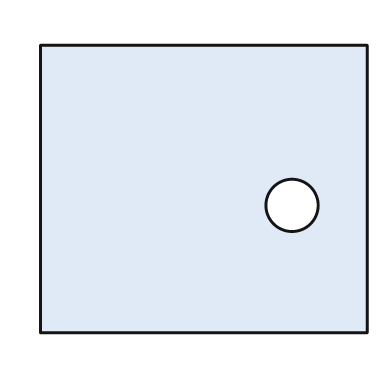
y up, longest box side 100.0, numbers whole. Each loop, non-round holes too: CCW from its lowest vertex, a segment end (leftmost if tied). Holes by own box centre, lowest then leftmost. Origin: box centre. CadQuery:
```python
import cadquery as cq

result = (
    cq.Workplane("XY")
    .moveTo(-50.0, -44.0)
    .lineTo(50.0, -44.0)
    .lineTo(50.0, 44.0)
    .lineTo(-50.0, 44.0)
    .close()
    .moveTo(27.0, -5.0)
    .circle(8.0)
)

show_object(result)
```